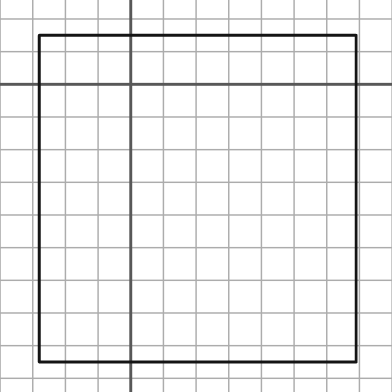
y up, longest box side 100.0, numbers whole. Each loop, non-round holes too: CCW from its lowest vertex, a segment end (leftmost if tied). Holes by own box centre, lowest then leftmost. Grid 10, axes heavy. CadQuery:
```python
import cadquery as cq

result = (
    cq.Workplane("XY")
    .moveTo(-28.0, -85.0)
    .lineTo(69.0, -85.0)
    .lineTo(69.0, 15.0)
    .lineTo(-28.0, 15.0)
    .close()
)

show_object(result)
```